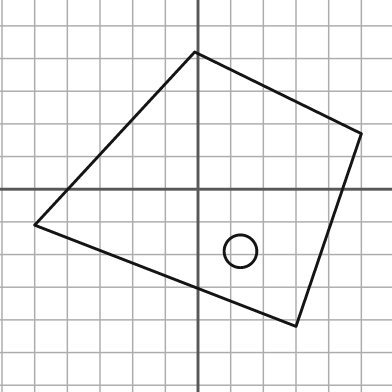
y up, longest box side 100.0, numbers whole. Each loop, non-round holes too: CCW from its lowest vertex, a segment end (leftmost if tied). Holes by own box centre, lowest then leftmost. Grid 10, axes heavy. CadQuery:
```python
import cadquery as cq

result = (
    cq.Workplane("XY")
    .moveTo(30.0, -42.0)
    .lineTo(50.0, 17.0)
    .lineTo(-1.0, 42.0)
    .lineTo(-50.0, -11.0)
    .close()
    .moveTo(13.0, -19.0)
    .circle(5.0)
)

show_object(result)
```